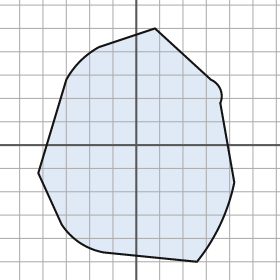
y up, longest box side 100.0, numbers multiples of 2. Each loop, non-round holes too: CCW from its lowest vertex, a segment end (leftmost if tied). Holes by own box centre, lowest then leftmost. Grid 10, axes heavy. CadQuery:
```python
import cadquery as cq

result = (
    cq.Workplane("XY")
    .moveTo(26.0, -50.0)
    .threePointArc((36.0, -34.0), (42.0, -16.0))
    .lineTo(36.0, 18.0)
    .threePointArc((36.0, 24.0), (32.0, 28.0))
    .lineTo(8.0, 50.0)
    .lineTo(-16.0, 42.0)
    .threePointArc((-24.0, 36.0), (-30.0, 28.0))
    .lineTo(-42.0, -12.0)
    .lineTo(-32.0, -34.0)
    .threePointArc((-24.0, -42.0), (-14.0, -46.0))
    .close()
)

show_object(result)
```